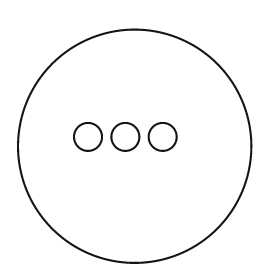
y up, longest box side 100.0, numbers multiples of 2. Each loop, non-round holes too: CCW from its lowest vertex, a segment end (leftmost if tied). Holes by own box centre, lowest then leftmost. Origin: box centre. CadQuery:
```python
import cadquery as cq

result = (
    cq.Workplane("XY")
    .moveTo(0.0, 0.0)
    .circle(50.0)
    .moveTo(-20.0, 4.0)
    .circle(6.0)
    .moveTo(-4.0, 4.0)
    .circle(6.0)
    .moveTo(12.0, 4.0)
    .circle(6.0)
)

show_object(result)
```